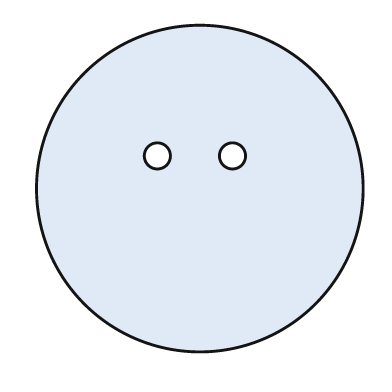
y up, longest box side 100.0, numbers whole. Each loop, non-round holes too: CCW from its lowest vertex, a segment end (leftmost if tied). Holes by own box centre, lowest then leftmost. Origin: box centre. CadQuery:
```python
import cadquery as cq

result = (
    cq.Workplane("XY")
    .moveTo(0.0, 0.0)
    .circle(50.0)
    .moveTo(-13.0, 10.0)
    .circle(4.0)
    .moveTo(10.0, 10.0)
    .circle(4.0)
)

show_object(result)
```